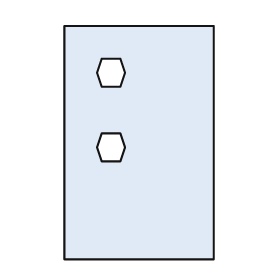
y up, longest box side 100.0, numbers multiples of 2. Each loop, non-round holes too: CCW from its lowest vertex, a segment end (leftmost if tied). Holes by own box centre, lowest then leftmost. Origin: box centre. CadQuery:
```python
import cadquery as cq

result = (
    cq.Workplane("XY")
    .moveTo(-32.0, -50.0)
    .lineTo(32.0, -50.0)
    .lineTo(32.0, 50.0)
    .lineTo(-32.0, 50.0)
    .close()
    .moveTo(-16.0, -8.0)
    .lineTo(-8.0, -8.0)
    .lineTo(-6.0, -2.0)
    .lineTo(-8.0, 4.0)
    .lineTo(-16.0, 4.0)
    .lineTo(-18.0, -2.0)
    .close()
    .moveTo(-16.0, 24.0)
    .lineTo(-8.0, 24.0)
    .lineTo(-6.0, 30.0)
    .lineTo(-8.0, 36.0)
    .lineTo(-16.0, 36.0)
    .lineTo(-18.0, 30.0)
    .close()
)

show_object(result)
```